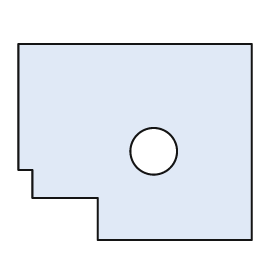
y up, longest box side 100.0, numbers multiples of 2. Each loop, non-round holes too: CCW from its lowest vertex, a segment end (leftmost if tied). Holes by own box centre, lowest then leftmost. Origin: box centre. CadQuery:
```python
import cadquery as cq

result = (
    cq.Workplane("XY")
    .moveTo(-16.0, -42.0)
    .lineTo(50.0, -42.0)
    .lineTo(50.0, 42.0)
    .lineTo(-50.0, 42.0)
    .lineTo(-50.0, -12.0)
    .lineTo(-44.0, -12.0)
    .lineTo(-44.0, -24.0)
    .lineTo(-16.0, -24.0)
    .close()
    .moveTo(8.0, -4.0)
    .circle(10.0)
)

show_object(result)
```